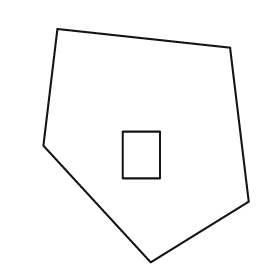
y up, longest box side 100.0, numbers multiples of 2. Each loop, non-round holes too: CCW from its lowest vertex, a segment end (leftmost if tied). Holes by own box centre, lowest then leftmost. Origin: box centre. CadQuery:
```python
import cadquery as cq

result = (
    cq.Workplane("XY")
    .moveTo(2.0, -50.0)
    .lineTo(44.0, -24.0)
    .lineTo(36.0, 42.0)
    .lineTo(-38.0, 50.0)
    .lineTo(-44.0, 0.0)
    .close()
    .moveTo(-10.0, -14.0)
    .lineTo(6.0, -14.0)
    .lineTo(6.0, 6.0)
    .lineTo(-10.0, 6.0)
    .close()
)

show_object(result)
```